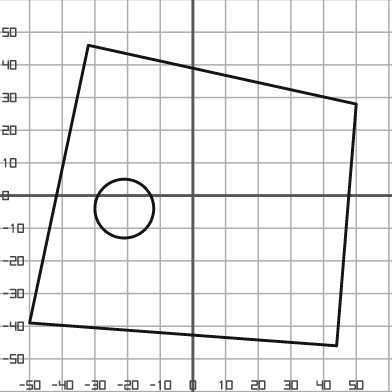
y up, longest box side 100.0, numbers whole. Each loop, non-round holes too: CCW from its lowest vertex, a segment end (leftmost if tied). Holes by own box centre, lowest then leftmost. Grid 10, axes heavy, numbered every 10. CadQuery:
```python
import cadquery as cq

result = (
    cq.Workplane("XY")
    .moveTo(44.0, -46.0)
    .lineTo(50.0, 28.0)
    .lineTo(-32.0, 46.0)
    .lineTo(-50.0, -39.0)
    .close()
    .moveTo(-21.0, -4.0)
    .circle(9.0)
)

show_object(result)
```